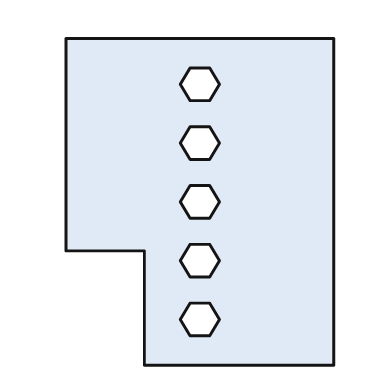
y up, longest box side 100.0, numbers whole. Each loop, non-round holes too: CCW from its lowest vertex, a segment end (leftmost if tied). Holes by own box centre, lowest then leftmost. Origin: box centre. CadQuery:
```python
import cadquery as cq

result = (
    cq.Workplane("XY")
    .moveTo(-17.0, -50.0)
    .lineTo(41.0, -50.0)
    .lineTo(41.0, 50.0)
    .lineTo(-41.0, 50.0)
    .lineTo(-41.0, -15.0)
    .lineTo(-17.0, -15.0)
    .close()
    .moveTo(-3.0, -41.0)
    .lineTo(3.0, -41.0)
    .lineTo(6.0, -36.0)
    .lineTo(3.0, -31.0)
    .lineTo(-3.0, -31.0)
    .lineTo(-6.0, -36.0)
    .close()
    .moveTo(-3.0, -23.0)
    .lineTo(3.0, -23.0)
    .lineTo(6.0, -18.0)
    .lineTo(3.0, -13.0)
    .lineTo(-3.0, -13.0)
    .lineTo(-6.0, -18.0)
    .close()
    .moveTo(-3.0, -5.0)
    .lineTo(3.0, -5.0)
    .lineTo(6.0, 0.0)
    .lineTo(3.0, 5.0)
    .lineTo(-3.0, 5.0)
    .lineTo(-6.0, 0.0)
    .close()
    .moveTo(-3.0, 13.0)
    .lineTo(3.0, 13.0)
    .lineTo(6.0, 18.0)
    .lineTo(3.0, 23.0)
    .lineTo(-3.0, 23.0)
    .lineTo(-6.0, 18.0)
    .close()
    .moveTo(-3.0, 31.0)
    .lineTo(3.0, 31.0)
    .lineTo(6.0, 36.0)
    .lineTo(3.0, 41.0)
    .lineTo(-3.0, 41.0)
    .lineTo(-6.0, 36.0)
    .close()
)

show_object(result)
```